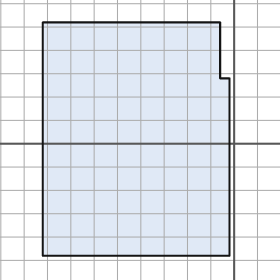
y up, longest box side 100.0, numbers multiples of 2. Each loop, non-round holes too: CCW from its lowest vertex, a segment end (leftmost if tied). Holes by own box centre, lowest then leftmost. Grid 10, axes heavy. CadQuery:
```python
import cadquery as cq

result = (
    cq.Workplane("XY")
    .moveTo(-82.0, -48.0)
    .lineTo(-2.0, -48.0)
    .lineTo(-2.0, 28.0)
    .lineTo(-6.0, 28.0)
    .lineTo(-6.0, 52.0)
    .lineTo(-82.0, 52.0)
    .close()
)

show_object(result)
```